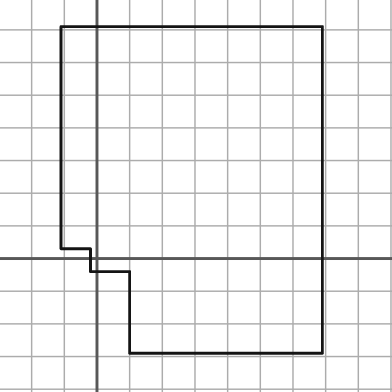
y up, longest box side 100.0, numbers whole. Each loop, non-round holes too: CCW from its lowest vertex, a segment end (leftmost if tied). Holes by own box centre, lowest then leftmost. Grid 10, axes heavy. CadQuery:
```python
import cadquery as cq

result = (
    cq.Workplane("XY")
    .moveTo(10.0, -29.0)
    .lineTo(69.0, -29.0)
    .lineTo(69.0, 71.0)
    .lineTo(-11.0, 71.0)
    .lineTo(-11.0, 3.0)
    .lineTo(-2.0, 3.0)
    .lineTo(-2.0, -4.0)
    .lineTo(10.0, -4.0)
    .close()
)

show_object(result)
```